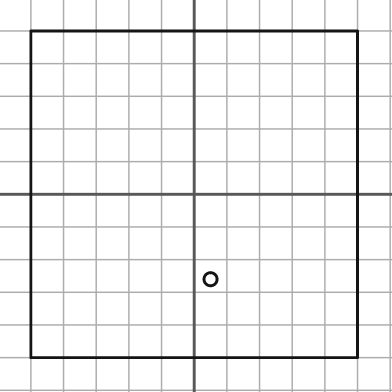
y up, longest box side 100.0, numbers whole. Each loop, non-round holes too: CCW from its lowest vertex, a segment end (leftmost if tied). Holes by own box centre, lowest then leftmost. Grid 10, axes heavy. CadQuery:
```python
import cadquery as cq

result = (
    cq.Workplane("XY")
    .moveTo(-50.0, -50.0)
    .lineTo(50.0, -50.0)
    .lineTo(50.0, 50.0)
    .lineTo(-50.0, 50.0)
    .close()
    .moveTo(5.0, -26.0)
    .circle(2.0)
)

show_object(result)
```